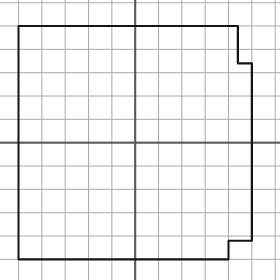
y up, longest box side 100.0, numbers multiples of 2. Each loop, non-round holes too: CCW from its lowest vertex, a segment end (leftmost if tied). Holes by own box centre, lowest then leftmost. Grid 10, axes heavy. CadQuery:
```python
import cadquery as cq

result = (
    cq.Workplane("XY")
    .moveTo(-50.0, -50.0)
    .lineTo(40.0, -50.0)
    .lineTo(40.0, -42.0)
    .lineTo(50.0, -42.0)
    .lineTo(50.0, 34.0)
    .lineTo(44.0, 34.0)
    .lineTo(44.0, 50.0)
    .lineTo(-50.0, 50.0)
    .close()
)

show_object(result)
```